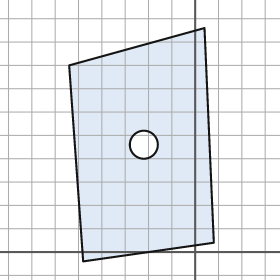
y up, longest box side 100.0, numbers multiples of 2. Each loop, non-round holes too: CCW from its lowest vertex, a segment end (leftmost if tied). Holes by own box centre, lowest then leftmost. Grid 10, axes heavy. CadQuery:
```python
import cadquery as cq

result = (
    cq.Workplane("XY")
    .moveTo(-48.0, -4.0)
    .lineTo(8.0, 4.0)
    .lineTo(4.0, 96.0)
    .lineTo(-54.0, 80.0)
    .close()
    .moveTo(-22.0, 46.0)
    .circle(6.0)
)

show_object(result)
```